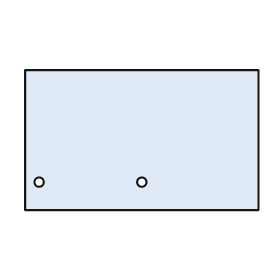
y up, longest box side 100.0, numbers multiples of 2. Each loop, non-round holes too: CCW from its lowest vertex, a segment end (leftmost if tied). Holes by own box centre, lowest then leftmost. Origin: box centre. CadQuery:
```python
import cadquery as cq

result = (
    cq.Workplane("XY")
    .moveTo(-50.0, -30.0)
    .lineTo(50.0, -30.0)
    .lineTo(50.0, 30.0)
    .lineTo(-50.0, 30.0)
    .close()
    .moveTo(-44.0, -18.0)
    .circle(2.0)
    .moveTo(0.0, -18.0)
    .circle(2.0)
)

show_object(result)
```